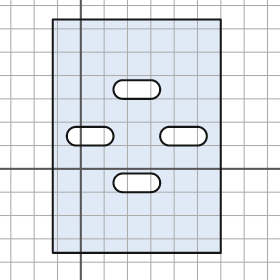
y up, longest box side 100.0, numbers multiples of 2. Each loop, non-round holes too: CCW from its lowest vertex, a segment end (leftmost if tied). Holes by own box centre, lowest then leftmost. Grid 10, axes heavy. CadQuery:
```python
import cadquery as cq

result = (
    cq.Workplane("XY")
    .moveTo(-12.0, -36.0)
    .lineTo(60.0, -36.0)
    .lineTo(60.0, 64.0)
    .lineTo(-12.0, 64.0)
    .close()
    .moveTo(18.0, -10.0)
    .lineTo(30.0, -10.0)
    .threePointArc((34.0, -6.0), (30.0, -2.0))
    .lineTo(18.0, -2.0)
    .threePointArc((14.0, -6.0), (18.0, -10.0))
    .close()
    .moveTo(-2.0, 10.0)
    .lineTo(10.0, 10.0)
    .threePointArc((14.0, 14.0), (10.0, 18.0))
    .lineTo(-2.0, 18.0)
    .threePointArc((-6.0, 14.0), (-2.0, 10.0))
    .close()
    .moveTo(38.0, 10.0)
    .lineTo(50.0, 10.0)
    .threePointArc((54.0, 14.0), (50.0, 18.0))
    .lineTo(38.0, 18.0)
    .threePointArc((34.0, 14.0), (38.0, 10.0))
    .close()
    .moveTo(18.0, 30.0)
    .lineTo(30.0, 30.0)
    .threePointArc((34.0, 34.0), (30.0, 38.0))
    .lineTo(18.0, 38.0)
    .threePointArc((14.0, 34.0), (18.0, 30.0))
    .close()
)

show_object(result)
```